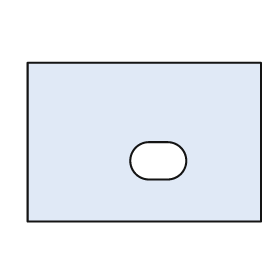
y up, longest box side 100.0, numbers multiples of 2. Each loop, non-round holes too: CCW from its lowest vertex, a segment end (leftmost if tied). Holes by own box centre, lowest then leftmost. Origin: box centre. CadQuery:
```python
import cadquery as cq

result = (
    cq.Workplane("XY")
    .moveTo(-50.0, -34.0)
    .lineTo(50.0, -34.0)
    .lineTo(50.0, 34.0)
    .lineTo(-50.0, 34.0)
    .close()
    .moveTo(2.0, -16.0)
    .lineTo(10.0, -16.0)
    .threePointArc((18.0, -8.0), (10.0, 0.0))
    .lineTo(2.0, 0.0)
    .threePointArc((-6.0, -8.0), (2.0, -16.0))
    .close()
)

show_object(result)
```